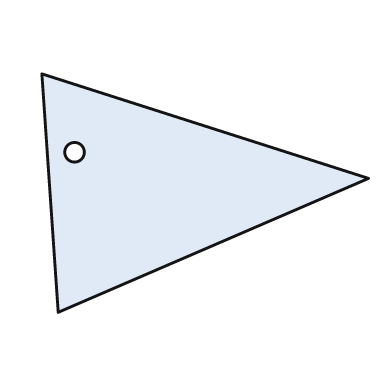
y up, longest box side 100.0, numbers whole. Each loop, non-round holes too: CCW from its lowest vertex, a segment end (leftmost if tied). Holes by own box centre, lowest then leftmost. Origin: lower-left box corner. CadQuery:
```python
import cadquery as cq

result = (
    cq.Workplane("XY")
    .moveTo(5.0, 0.0)
    .lineTo(100.0, 41.0)
    .lineTo(0.0, 73.0)
    .close()
    .moveTo(10.0, 49.0)
    .circle(3.0)
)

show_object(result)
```